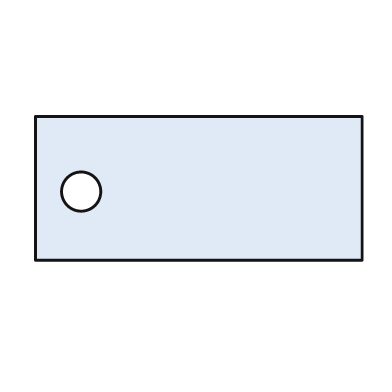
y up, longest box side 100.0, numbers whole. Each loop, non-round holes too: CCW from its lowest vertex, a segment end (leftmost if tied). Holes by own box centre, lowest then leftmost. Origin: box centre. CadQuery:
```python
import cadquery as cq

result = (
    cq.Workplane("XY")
    .moveTo(-50.0, -22.0)
    .lineTo(50.0, -22.0)
    .lineTo(50.0, 22.0)
    .lineTo(-50.0, 22.0)
    .close()
    .moveTo(-36.0, -1.0)
    .circle(6.0)
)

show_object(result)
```